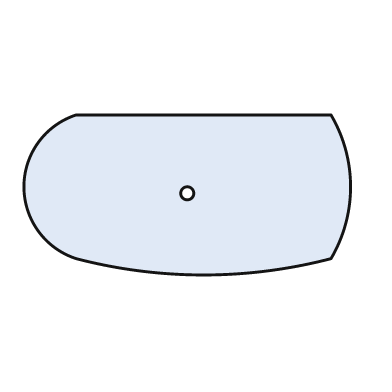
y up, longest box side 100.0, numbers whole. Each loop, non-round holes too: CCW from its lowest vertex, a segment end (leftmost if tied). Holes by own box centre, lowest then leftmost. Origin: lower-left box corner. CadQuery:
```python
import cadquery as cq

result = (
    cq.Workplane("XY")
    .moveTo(16.0, 5.0)
    .threePointArc((55.0, 0.0), (94.0, 5.0))
    .threePointArc((100.0, 27.0), (94.0, 49.0))
    .lineTo(16.0, 49.0)
    .threePointArc((0.0, 27.0), (16.0, 5.0))
    .close()
    .moveTo(50.0, 25.0)
    .circle(2.0)
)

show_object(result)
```